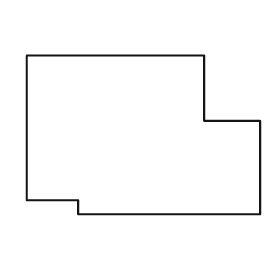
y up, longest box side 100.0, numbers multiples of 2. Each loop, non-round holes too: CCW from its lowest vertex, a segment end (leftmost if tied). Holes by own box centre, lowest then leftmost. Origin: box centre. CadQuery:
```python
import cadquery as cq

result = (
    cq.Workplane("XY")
    .moveTo(-28.0, -34.0)
    .lineTo(50.0, -34.0)
    .lineTo(50.0, 6.0)
    .lineTo(26.0, 6.0)
    .lineTo(26.0, 34.0)
    .lineTo(-50.0, 34.0)
    .lineTo(-50.0, -28.0)
    .lineTo(-28.0, -28.0)
    .close()
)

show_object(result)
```